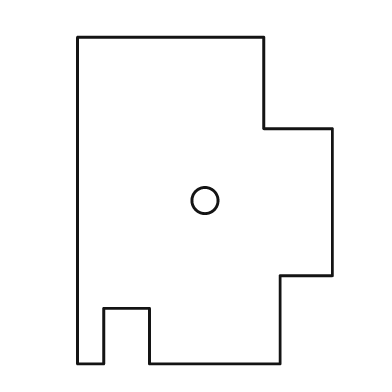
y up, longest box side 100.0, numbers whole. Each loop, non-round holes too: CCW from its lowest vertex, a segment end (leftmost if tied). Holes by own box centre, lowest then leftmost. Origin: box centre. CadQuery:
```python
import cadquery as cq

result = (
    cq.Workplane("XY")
    .moveTo(-39.0, -50.0)
    .lineTo(-31.0, -50.0)
    .lineTo(-31.0, -33.0)
    .lineTo(-17.0, -33.0)
    .lineTo(-17.0, -50.0)
    .lineTo(23.0, -50.0)
    .lineTo(23.0, -23.0)
    .lineTo(39.0, -23.0)
    .lineTo(39.0, 22.0)
    .lineTo(18.0, 22.0)
    .lineTo(18.0, 50.0)
    .lineTo(-39.0, 50.0)
    .close()
    .moveTo(0.0, 0.0)
    .circle(4.0)
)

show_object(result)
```